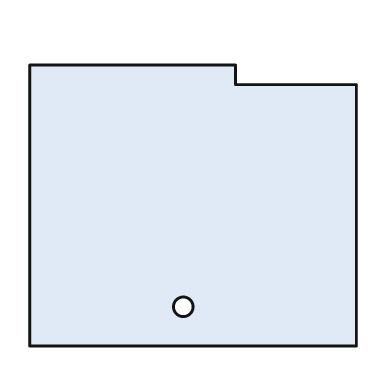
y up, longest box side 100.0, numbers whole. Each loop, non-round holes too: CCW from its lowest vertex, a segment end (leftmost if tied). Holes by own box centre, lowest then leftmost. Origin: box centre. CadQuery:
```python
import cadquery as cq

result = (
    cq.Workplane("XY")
    .moveTo(-50.0, -43.0)
    .lineTo(50.0, -43.0)
    .lineTo(50.0, 37.0)
    .lineTo(13.0, 37.0)
    .lineTo(13.0, 43.0)
    .lineTo(-50.0, 43.0)
    .close()
    .moveTo(-3.0, -31.0)
    .circle(3.0)
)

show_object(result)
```